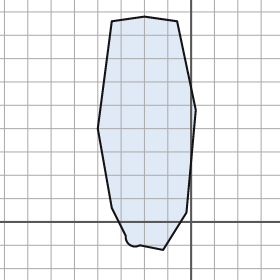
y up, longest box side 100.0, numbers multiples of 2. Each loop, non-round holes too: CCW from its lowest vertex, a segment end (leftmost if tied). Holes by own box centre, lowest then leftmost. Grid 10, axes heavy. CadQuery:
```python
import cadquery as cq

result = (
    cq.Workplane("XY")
    .moveTo(-12.0, -12.0)
    .lineTo(-2.0, 4.0)
    .lineTo(2.0, 48.0)
    .lineTo(-6.0, 86.0)
    .lineTo(-20.0, 88.0)
    .lineTo(-34.0, 86.0)
    .lineTo(-40.0, 40.0)
    .lineTo(-34.0, 6.0)
    .lineTo(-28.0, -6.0)
    .threePointArc((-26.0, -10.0), (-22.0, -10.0))
    .close()
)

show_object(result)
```